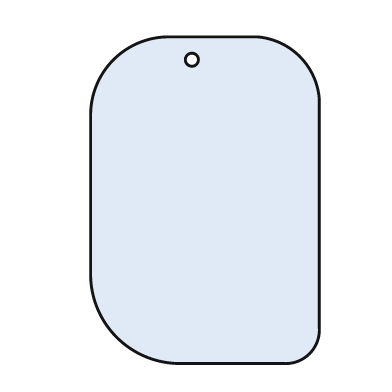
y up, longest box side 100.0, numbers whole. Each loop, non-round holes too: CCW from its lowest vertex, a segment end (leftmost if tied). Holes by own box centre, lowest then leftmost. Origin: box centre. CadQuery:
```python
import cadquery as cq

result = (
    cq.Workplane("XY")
    .moveTo(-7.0, -50.0)
    .lineTo(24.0, -50.0)
    .threePointArc((32.0, -47.0), (35.0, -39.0))
    .lineTo(35.0, 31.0)
    .threePointArc((29.0, 44.0), (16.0, 50.0))
    .lineTo(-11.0, 50.0)
    .threePointArc((-28.0, 43.0), (-35.0, 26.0))
    .lineTo(-35.0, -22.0)
    .threePointArc((-27.0, -42.0), (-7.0, -50.0))
    .close()
    .moveTo(-4.0, 43.0)
    .circle(2.0)
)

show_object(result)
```